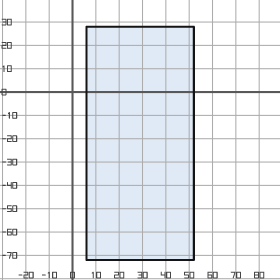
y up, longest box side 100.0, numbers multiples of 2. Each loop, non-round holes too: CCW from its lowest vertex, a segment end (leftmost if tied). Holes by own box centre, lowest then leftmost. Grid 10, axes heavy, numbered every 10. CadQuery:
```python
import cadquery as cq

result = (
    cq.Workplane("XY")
    .moveTo(6.0, -72.0)
    .lineTo(52.0, -72.0)
    .lineTo(52.0, 28.0)
    .lineTo(6.0, 28.0)
    .close()
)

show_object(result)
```